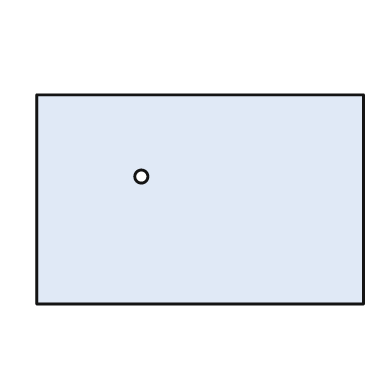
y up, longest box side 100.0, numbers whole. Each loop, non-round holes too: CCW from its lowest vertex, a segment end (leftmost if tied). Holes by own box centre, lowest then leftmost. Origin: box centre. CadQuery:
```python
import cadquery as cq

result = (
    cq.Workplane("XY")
    .moveTo(-50.0, -32.0)
    .lineTo(50.0, -32.0)
    .lineTo(50.0, 32.0)
    .lineTo(-50.0, 32.0)
    .close()
    .moveTo(-18.0, 7.0)
    .circle(2.0)
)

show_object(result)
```